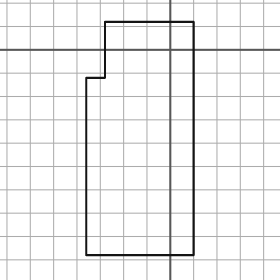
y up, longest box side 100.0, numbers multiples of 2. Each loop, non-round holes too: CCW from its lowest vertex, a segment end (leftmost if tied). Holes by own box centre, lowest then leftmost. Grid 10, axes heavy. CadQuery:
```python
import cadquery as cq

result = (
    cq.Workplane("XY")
    .moveTo(-36.0, -88.0)
    .lineTo(10.0, -88.0)
    .lineTo(10.0, 12.0)
    .lineTo(-28.0, 12.0)
    .lineTo(-28.0, -12.0)
    .lineTo(-36.0, -12.0)
    .close()
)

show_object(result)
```